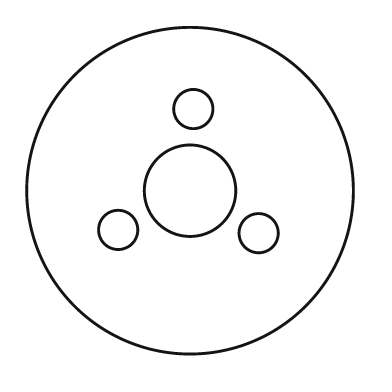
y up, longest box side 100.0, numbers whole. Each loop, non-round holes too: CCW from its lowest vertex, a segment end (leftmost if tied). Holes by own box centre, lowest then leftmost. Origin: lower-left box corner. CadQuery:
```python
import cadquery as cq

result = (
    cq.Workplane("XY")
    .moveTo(50.0, 50.0)
    .circle(50.0)
    .moveTo(71.0, 37.0)
    .circle(6.0)
    .moveTo(28.0, 38.0)
    .circle(6.0)
    .moveTo(50.0, 50.0)
    .circle(14.0)
    .moveTo(51.0, 75.0)
    .circle(6.0)
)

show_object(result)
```